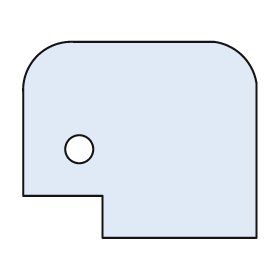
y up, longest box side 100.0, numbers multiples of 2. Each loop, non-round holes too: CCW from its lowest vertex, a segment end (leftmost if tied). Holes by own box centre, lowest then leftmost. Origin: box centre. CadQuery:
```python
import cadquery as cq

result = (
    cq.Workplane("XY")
    .moveTo(-16.0, -42.0)
    .lineTo(50.0, -42.0)
    .lineTo(50.0, 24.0)
    .threePointArc((44.0, 36.0), (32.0, 42.0))
    .lineTo(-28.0, 42.0)
    .threePointArc((-44.0, 36.0), (-50.0, 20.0))
    .lineTo(-50.0, -24.0)
    .lineTo(-16.0, -24.0)
    .close()
    .moveTo(-26.0, -4.0)
    .circle(6.0)
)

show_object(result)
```